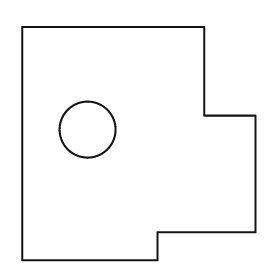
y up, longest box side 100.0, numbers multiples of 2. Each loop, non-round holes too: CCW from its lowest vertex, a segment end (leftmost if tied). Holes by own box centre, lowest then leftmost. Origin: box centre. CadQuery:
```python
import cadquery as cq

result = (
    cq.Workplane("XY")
    .moveTo(-50.0, -50.0)
    .lineTo(8.0, -50.0)
    .lineTo(8.0, -38.0)
    .lineTo(50.0, -38.0)
    .lineTo(50.0, 12.0)
    .lineTo(28.0, 12.0)
    .lineTo(28.0, 50.0)
    .lineTo(-50.0, 50.0)
    .close()
    .moveTo(-22.0, 6.0)
    .circle(12.0)
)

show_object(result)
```